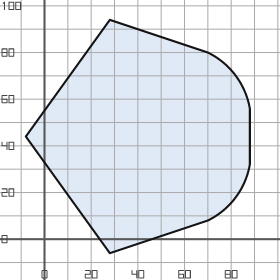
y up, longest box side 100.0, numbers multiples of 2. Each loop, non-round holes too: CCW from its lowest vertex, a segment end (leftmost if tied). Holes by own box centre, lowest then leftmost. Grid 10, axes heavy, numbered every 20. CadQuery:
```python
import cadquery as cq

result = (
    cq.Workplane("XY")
    .moveTo(28.0, -6.0)
    .lineTo(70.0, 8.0)
    .threePointArc((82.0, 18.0), (88.0, 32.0))
    .lineTo(88.0, 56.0)
    .threePointArc((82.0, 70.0), (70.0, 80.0))
    .lineTo(28.0, 94.0)
    .lineTo(-8.0, 44.0)
    .close()
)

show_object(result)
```